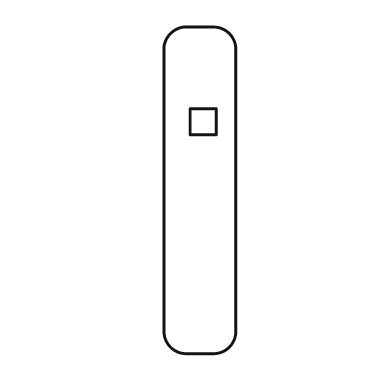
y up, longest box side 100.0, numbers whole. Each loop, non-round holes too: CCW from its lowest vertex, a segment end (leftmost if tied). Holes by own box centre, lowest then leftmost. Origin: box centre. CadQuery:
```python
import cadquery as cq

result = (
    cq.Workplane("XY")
    .moveTo(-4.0, -50.0)
    .lineTo(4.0, -50.0)
    .threePointArc((9.0, -48.0), (11.0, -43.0))
    .lineTo(11.0, 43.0)
    .threePointArc((9.0, 48.0), (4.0, 50.0))
    .lineTo(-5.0, 50.0)
    .threePointArc((-9.0, 48.0), (-11.0, 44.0))
    .lineTo(-11.0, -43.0)
    .threePointArc((-9.0, -48.0), (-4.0, -50.0))
    .close()
    .moveTo(-3.0, 17.0)
    .lineTo(5.0, 17.0)
    .lineTo(5.0, 25.0)
    .lineTo(-3.0, 25.0)
    .close()
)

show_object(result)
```